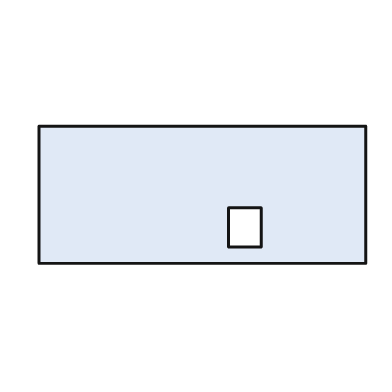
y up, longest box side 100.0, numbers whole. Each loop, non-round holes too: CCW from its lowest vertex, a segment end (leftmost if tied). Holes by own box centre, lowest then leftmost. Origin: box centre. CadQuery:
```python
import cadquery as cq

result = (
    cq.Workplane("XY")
    .moveTo(-50.0, -21.0)
    .lineTo(50.0, -21.0)
    .lineTo(50.0, 21.0)
    .lineTo(-50.0, 21.0)
    .close()
    .moveTo(8.0, -16.0)
    .lineTo(18.0, -16.0)
    .lineTo(18.0, -4.0)
    .lineTo(8.0, -4.0)
    .close()
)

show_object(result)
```